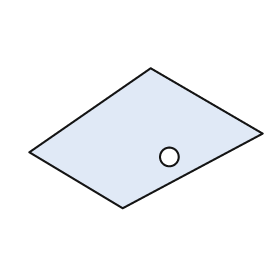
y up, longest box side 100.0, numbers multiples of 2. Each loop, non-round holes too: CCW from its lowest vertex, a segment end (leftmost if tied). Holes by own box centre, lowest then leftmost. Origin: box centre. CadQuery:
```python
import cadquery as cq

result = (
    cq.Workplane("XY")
    .moveTo(-10.0, -30.0)
    .lineTo(50.0, 2.0)
    .lineTo(2.0, 30.0)
    .lineTo(-50.0, -6.0)
    .close()
    .moveTo(10.0, -8.0)
    .circle(4.0)
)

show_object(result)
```